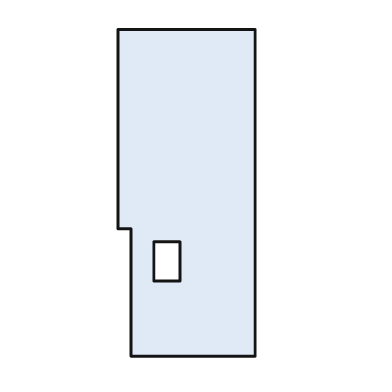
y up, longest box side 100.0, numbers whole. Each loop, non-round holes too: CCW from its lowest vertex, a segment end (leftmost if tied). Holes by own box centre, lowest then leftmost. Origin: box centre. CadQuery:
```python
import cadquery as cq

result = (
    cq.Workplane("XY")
    .moveTo(-17.0, -50.0)
    .lineTo(21.0, -50.0)
    .lineTo(21.0, 50.0)
    .lineTo(-21.0, 50.0)
    .lineTo(-21.0, -11.0)
    .lineTo(-17.0, -11.0)
    .close()
    .moveTo(-10.0, -27.0)
    .lineTo(-2.0, -27.0)
    .lineTo(-2.0, -15.0)
    .lineTo(-10.0, -15.0)
    .close()
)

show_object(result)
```